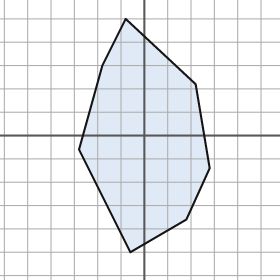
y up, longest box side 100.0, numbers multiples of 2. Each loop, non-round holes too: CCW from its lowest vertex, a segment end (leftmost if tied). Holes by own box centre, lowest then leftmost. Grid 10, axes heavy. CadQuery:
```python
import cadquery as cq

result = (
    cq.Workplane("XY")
    .moveTo(-6.0, -50.0)
    .lineTo(18.0, -36.0)
    .lineTo(28.0, -14.0)
    .lineTo(22.0, 22.0)
    .lineTo(-8.0, 50.0)
    .lineTo(-18.0, 30.0)
    .lineTo(-28.0, -6.0)
    .close()
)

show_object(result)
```